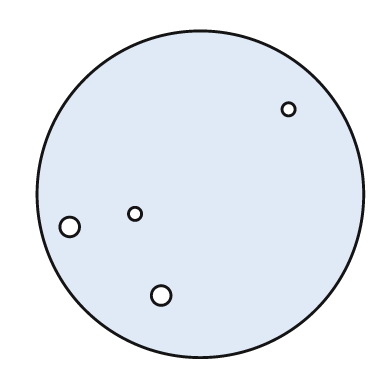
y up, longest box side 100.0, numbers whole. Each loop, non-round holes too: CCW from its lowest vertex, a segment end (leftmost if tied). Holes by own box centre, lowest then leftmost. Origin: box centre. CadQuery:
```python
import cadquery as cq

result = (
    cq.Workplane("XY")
    .moveTo(0.0, 0.0)
    .circle(50.0)
    .moveTo(-12.0, -31.0)
    .circle(3.0)
    .moveTo(-40.0, -10.0)
    .circle(3.0)
    .moveTo(-20.0, -6.0)
    .circle(2.0)
    .moveTo(27.0, 26.0)
    .circle(2.0)
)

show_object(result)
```